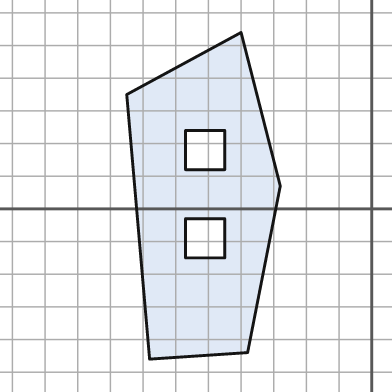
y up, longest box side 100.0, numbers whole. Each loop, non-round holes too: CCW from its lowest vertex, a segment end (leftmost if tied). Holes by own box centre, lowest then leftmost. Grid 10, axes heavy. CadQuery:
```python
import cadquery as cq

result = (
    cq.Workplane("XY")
    .moveTo(-68.0, -46.0)
    .lineTo(-38.0, -44.0)
    .lineTo(-28.0, 7.0)
    .lineTo(-40.0, 54.0)
    .lineTo(-75.0, 35.0)
    .close()
    .moveTo(-57.0, -15.0)
    .lineTo(-45.0, -15.0)
    .lineTo(-45.0, -3.0)
    .lineTo(-57.0, -3.0)
    .close()
    .moveTo(-57.0, 12.0)
    .lineTo(-45.0, 12.0)
    .lineTo(-45.0, 24.0)
    .lineTo(-57.0, 24.0)
    .close()
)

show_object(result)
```